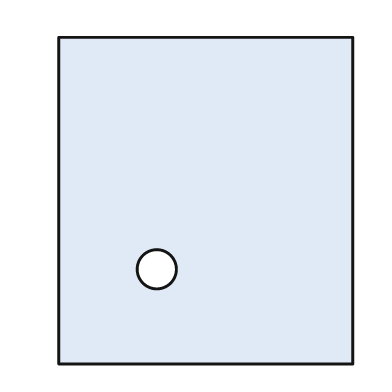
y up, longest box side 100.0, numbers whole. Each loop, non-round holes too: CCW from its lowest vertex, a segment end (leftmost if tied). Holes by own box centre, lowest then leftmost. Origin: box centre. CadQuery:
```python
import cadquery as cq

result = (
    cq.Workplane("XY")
    .moveTo(-45.0, -50.0)
    .lineTo(45.0, -50.0)
    .lineTo(45.0, 50.0)
    .lineTo(-45.0, 50.0)
    .close()
    .moveTo(-15.0, -21.0)
    .circle(6.0)
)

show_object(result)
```